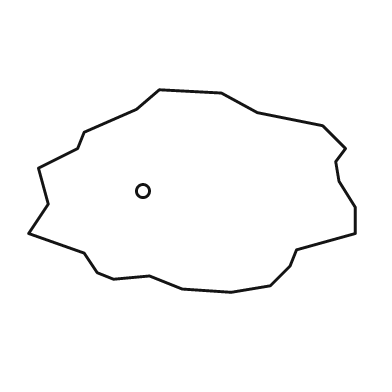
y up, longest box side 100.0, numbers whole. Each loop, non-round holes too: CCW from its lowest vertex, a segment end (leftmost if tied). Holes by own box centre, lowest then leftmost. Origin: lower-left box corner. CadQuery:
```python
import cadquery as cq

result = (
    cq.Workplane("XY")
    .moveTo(62.0, 0.0)
    .lineTo(74.0, 2.0)
    .lineTo(80.0, 8.0)
    .lineTo(82.0, 13.0)
    .lineTo(100.0, 18.0)
    .lineTo(100.0, 26.0)
    .lineTo(95.0, 34.0)
    .lineTo(94.0, 40.0)
    .lineTo(97.0, 44.0)
    .lineTo(90.0, 51.0)
    .lineTo(70.0, 55.0)
    .lineTo(59.0, 61.0)
    .lineTo(40.0, 62.0)
    .lineTo(33.0, 56.0)
    .lineTo(17.0, 49.0)
    .lineTo(15.0, 44.0)
    .lineTo(3.0, 38.0)
    .lineTo(6.0, 27.0)
    .lineTo(0.0, 18.0)
    .lineTo(17.0, 12.0)
    .lineTo(21.0, 6.0)
    .lineTo(26.0, 4.0)
    .lineTo(37.0, 5.0)
    .lineTo(47.0, 1.0)
    .close()
    .moveTo(35.0, 31.0)
    .circle(2.0)
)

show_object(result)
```